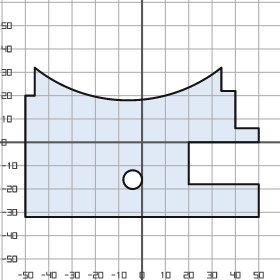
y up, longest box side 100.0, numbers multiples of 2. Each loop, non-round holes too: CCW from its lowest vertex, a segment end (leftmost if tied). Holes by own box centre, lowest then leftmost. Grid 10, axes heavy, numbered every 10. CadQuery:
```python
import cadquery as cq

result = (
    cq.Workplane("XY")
    .moveTo(-50.0, -32.0)
    .lineTo(50.0, -32.0)
    .lineTo(50.0, -18.0)
    .lineTo(20.0, -18.0)
    .lineTo(20.0, 0.0)
    .lineTo(50.0, 0.0)
    .lineTo(50.0, 6.0)
    .lineTo(40.0, 6.0)
    .lineTo(40.0, 22.0)
    .lineTo(34.0, 22.0)
    .lineTo(34.0, 32.0)
    .threePointArc((-6.0, 18.0), (-46.0, 32.0))
    .lineTo(-46.0, 20.0)
    .lineTo(-50.0, 20.0)
    .close()
    .moveTo(-4.0, -16.0)
    .circle(4.0)
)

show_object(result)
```